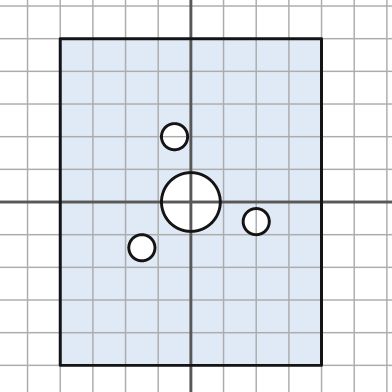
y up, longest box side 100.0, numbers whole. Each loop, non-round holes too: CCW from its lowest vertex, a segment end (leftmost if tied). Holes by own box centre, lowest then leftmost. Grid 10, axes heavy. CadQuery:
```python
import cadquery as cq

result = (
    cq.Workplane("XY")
    .moveTo(-40.0, -50.0)
    .lineTo(40.0, -50.0)
    .lineTo(40.0, 50.0)
    .lineTo(-40.0, 50.0)
    .close()
    .moveTo(-15.0, -14.0)
    .circle(4.0)
    .moveTo(20.0, -6.0)
    .circle(4.0)
    .moveTo(0.0, 0.0)
    .circle(9.0)
    .moveTo(-5.0, 20.0)
    .circle(4.0)
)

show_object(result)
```